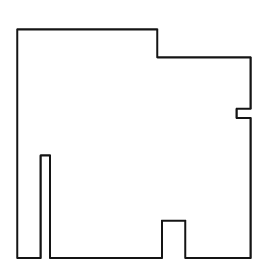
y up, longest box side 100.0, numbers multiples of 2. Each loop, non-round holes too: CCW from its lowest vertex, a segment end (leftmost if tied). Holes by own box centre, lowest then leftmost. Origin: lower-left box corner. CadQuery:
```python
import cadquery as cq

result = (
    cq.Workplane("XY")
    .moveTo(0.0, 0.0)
    .lineTo(10.0, 0.0)
    .lineTo(10.0, 44.0)
    .lineTo(14.0, 44.0)
    .lineTo(14.0, 0.0)
    .lineTo(62.0, 0.0)
    .lineTo(62.0, 16.0)
    .lineTo(72.0, 16.0)
    .lineTo(72.0, 0.0)
    .lineTo(100.0, 0.0)
    .lineTo(100.0, 60.0)
    .lineTo(94.0, 60.0)
    .lineTo(94.0, 64.0)
    .lineTo(100.0, 64.0)
    .lineTo(100.0, 86.0)
    .lineTo(60.0, 86.0)
    .lineTo(60.0, 98.0)
    .lineTo(0.0, 98.0)
    .close()
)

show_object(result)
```